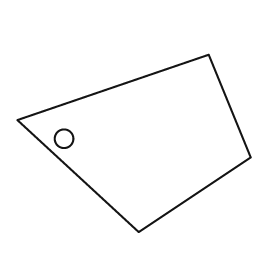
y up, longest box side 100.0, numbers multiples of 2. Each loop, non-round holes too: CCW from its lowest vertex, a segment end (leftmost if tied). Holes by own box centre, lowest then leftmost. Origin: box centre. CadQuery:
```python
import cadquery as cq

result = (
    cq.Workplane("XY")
    .moveTo(2.0, -38.0)
    .lineTo(50.0, -6.0)
    .lineTo(32.0, 38.0)
    .lineTo(-50.0, 10.0)
    .close()
    .moveTo(-30.0, 2.0)
    .circle(4.0)
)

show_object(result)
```